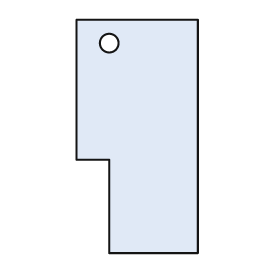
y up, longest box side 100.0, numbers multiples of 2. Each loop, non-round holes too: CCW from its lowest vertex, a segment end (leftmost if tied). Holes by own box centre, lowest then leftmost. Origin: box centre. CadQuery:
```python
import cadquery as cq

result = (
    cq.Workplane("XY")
    .moveTo(-12.0, -50.0)
    .lineTo(26.0, -50.0)
    .lineTo(26.0, 50.0)
    .lineTo(-26.0, 50.0)
    .lineTo(-26.0, -10.0)
    .lineTo(-12.0, -10.0)
    .close()
    .moveTo(-12.0, 40.0)
    .circle(4.0)
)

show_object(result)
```